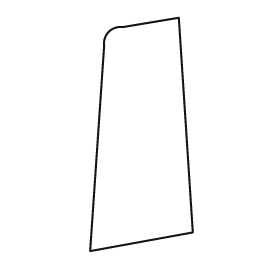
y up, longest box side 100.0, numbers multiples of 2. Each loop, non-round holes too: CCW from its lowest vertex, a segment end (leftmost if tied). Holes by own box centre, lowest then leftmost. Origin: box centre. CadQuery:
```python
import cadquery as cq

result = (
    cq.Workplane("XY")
    .moveTo(-22.0, -50.0)
    .lineTo(22.0, -42.0)
    .lineTo(16.0, 50.0)
    .lineTo(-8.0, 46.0)
    .threePointArc((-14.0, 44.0), (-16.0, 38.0))
    .close()
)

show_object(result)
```